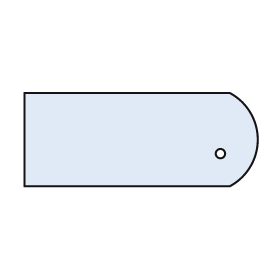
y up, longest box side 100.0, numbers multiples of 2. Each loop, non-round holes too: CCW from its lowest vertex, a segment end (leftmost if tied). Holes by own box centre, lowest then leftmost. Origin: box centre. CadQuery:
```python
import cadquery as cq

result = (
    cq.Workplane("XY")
    .moveTo(-50.0, -20.0)
    .lineTo(38.0, -20.0)
    .threePointArc((50.0, 0.0), (38.0, 20.0))
    .lineTo(-50.0, 20.0)
    .close()
    .moveTo(34.0, -6.0)
    .circle(2.0)
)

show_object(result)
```